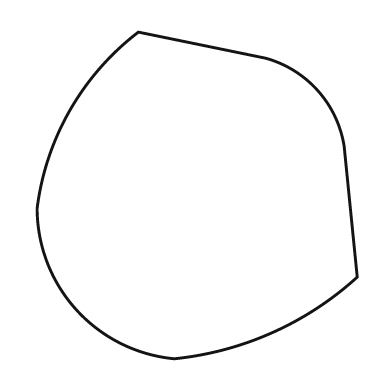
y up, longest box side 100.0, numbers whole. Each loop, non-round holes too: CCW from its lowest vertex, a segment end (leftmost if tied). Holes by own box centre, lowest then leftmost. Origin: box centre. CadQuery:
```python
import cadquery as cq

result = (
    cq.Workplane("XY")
    .moveTo(-7.0, -50.0)
    .threePointArc((23.0, -42.0), (49.0, -25.0))
    .lineTo(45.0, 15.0)
    .threePointArc((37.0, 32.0), (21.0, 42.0))
    .lineTo(-18.0, 50.0)
    .threePointArc((-39.0, 26.0), (-49.0, -4.0))
    .threePointArc((-37.0, -35.0), (-7.0, -50.0))
    .close()
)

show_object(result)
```